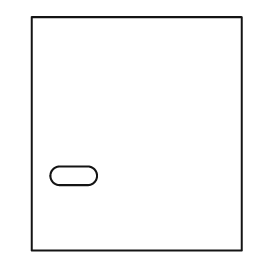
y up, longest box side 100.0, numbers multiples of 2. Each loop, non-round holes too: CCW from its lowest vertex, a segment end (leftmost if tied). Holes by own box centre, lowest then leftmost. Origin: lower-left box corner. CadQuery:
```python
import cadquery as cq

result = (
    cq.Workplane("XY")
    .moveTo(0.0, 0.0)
    .lineTo(90.0, 0.0)
    .lineTo(90.0, 100.0)
    .lineTo(0.0, 100.0)
    .close()
    .moveTo(12.0, 28.0)
    .lineTo(24.0, 28.0)
    .threePointArc((28.0, 32.0), (24.0, 36.0))
    .lineTo(12.0, 36.0)
    .threePointArc((8.0, 32.0), (12.0, 28.0))
    .close()
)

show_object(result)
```